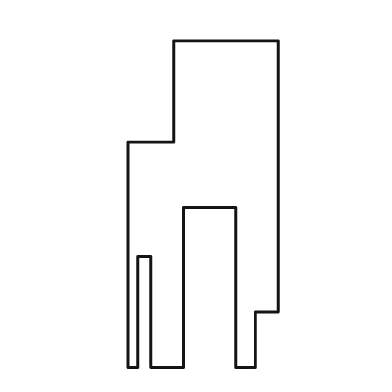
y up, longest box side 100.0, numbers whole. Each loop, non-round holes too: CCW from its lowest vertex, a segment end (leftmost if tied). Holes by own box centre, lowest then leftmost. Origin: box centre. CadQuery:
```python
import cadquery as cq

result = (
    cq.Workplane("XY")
    .moveTo(-23.0, -50.0)
    .lineTo(-20.0, -50.0)
    .lineTo(-20.0, -16.0)
    .lineTo(-16.0, -16.0)
    .lineTo(-16.0, -50.0)
    .lineTo(-6.0, -50.0)
    .lineTo(-6.0, -1.0)
    .lineTo(10.0, -1.0)
    .lineTo(10.0, -50.0)
    .lineTo(16.0, -50.0)
    .lineTo(16.0, -33.0)
    .lineTo(23.0, -33.0)
    .lineTo(23.0, 50.0)
    .lineTo(-9.0, 50.0)
    .lineTo(-9.0, 19.0)
    .lineTo(-23.0, 19.0)
    .close()
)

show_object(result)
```